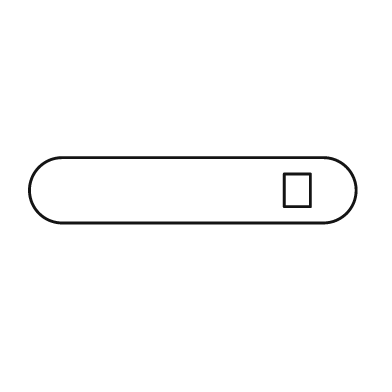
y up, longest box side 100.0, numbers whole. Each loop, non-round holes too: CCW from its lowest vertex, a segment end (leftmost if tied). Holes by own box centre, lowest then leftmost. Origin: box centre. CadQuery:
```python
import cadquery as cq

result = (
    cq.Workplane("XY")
    .moveTo(-40.0, -10.0)
    .lineTo(40.0, -10.0)
    .threePointArc((50.0, 0.0), (40.0, 10.0))
    .lineTo(-40.0, 10.0)
    .threePointArc((-50.0, 0.0), (-40.0, -10.0))
    .close()
    .moveTo(28.0, -5.0)
    .lineTo(36.0, -5.0)
    .lineTo(36.0, 5.0)
    .lineTo(28.0, 5.0)
    .close()
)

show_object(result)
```